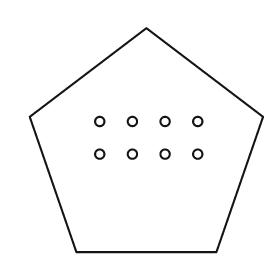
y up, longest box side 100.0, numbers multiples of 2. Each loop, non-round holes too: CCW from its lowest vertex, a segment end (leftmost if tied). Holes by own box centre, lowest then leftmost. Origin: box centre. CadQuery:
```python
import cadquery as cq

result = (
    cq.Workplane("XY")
    .moveTo(-30.0, -48.0)
    .lineTo(30.0, -48.0)
    .lineTo(50.0, 10.0)
    .lineTo(0.0, 48.0)
    .lineTo(-50.0, 10.0)
    .close()
    .moveTo(-20.0, -6.0)
    .circle(2.0)
    .moveTo(-6.0, -6.0)
    .circle(2.0)
    .moveTo(8.0, -6.0)
    .circle(2.0)
    .moveTo(22.0, -6.0)
    .circle(2.0)
    .moveTo(-20.0, 8.0)
    .circle(2.0)
    .moveTo(-6.0, 8.0)
    .circle(2.0)
    .moveTo(8.0, 8.0)
    .circle(2.0)
    .moveTo(22.0, 8.0)
    .circle(2.0)
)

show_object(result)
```